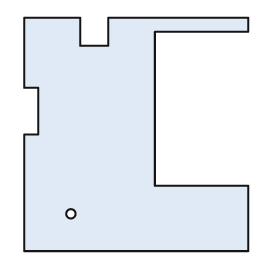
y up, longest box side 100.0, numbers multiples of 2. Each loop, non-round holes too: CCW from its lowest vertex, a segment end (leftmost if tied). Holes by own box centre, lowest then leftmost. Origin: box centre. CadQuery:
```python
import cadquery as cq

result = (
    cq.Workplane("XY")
    .moveTo(-48.0, -50.0)
    .lineTo(48.0, -50.0)
    .lineTo(48.0, -22.0)
    .lineTo(8.0, -22.0)
    .lineTo(8.0, 44.0)
    .lineTo(48.0, 44.0)
    .lineTo(48.0, 50.0)
    .lineTo(-12.0, 50.0)
    .lineTo(-12.0, 38.0)
    .lineTo(-24.0, 38.0)
    .lineTo(-24.0, 50.0)
    .lineTo(-48.0, 50.0)
    .lineTo(-48.0, 20.0)
    .lineTo(-42.0, 20.0)
    .lineTo(-42.0, 0.0)
    .lineTo(-48.0, 0.0)
    .close()
    .moveTo(-28.0, -34.0)
    .circle(2.0)
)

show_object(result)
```